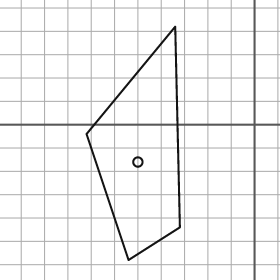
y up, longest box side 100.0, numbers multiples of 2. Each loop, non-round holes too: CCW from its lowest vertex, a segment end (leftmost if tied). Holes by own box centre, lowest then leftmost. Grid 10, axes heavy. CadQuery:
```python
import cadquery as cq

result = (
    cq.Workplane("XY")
    .moveTo(-54.0, -58.0)
    .lineTo(-32.0, -44.0)
    .lineTo(-34.0, 42.0)
    .lineTo(-72.0, -4.0)
    .close()
    .moveTo(-50.0, -16.0)
    .circle(2.0)
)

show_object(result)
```